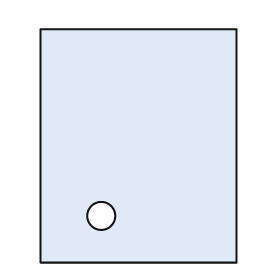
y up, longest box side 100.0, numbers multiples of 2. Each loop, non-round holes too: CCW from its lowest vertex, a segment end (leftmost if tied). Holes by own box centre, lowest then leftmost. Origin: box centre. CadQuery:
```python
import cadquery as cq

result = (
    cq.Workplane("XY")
    .moveTo(-42.0, -50.0)
    .lineTo(42.0, -50.0)
    .lineTo(42.0, 50.0)
    .lineTo(-42.0, 50.0)
    .close()
    .moveTo(-16.0, -30.0)
    .circle(6.0)
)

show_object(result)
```